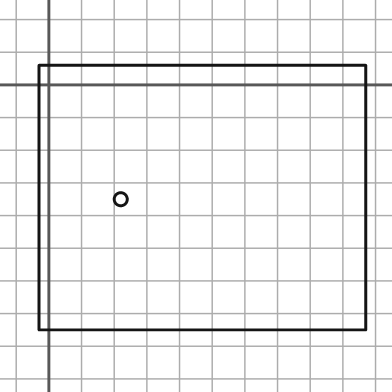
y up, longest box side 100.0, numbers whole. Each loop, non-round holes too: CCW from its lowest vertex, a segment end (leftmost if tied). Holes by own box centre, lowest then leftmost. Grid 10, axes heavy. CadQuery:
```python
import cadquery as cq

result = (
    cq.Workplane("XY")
    .moveTo(-3.0, -75.0)
    .lineTo(97.0, -75.0)
    .lineTo(97.0, 6.0)
    .lineTo(-3.0, 6.0)
    .close()
    .moveTo(22.0, -35.0)
    .circle(2.0)
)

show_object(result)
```